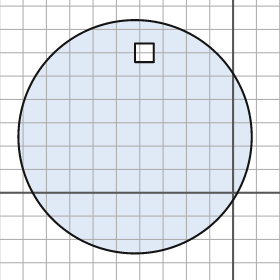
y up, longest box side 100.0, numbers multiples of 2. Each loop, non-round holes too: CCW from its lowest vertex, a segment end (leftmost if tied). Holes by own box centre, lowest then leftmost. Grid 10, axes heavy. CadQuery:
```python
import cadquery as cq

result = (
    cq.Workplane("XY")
    .moveTo(-42.0, 24.0)
    .circle(50.0)
    .moveTo(-42.0, 56.0)
    .lineTo(-34.0, 56.0)
    .lineTo(-34.0, 64.0)
    .lineTo(-42.0, 64.0)
    .close()
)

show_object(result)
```